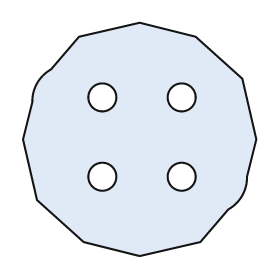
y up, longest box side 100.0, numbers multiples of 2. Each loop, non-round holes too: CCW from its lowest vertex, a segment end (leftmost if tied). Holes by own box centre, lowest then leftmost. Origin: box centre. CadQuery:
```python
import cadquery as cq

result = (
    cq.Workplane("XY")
    .moveTo(0.0, -50.0)
    .lineTo(26.0, -44.0)
    .lineTo(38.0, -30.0)
    .threePointArc((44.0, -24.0), (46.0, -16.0))
    .lineTo(50.0, 0.0)
    .lineTo(44.0, 26.0)
    .lineTo(24.0, 44.0)
    .lineTo(0.0, 50.0)
    .lineTo(-26.0, 44.0)
    .lineTo(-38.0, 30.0)
    .threePointArc((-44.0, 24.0), (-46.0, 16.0))
    .lineTo(-50.0, 0.0)
    .lineTo(-44.0, -26.0)
    .lineTo(-24.0, -44.0)
    .close()
    .moveTo(-16.0, -16.0)
    .circle(6.0)
    .moveTo(18.0, -16.0)
    .circle(6.0)
    .moveTo(-16.0, 18.0)
    .circle(6.0)
    .moveTo(18.0, 18.0)
    .circle(6.0)
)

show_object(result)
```